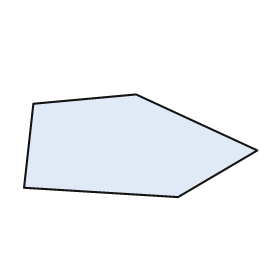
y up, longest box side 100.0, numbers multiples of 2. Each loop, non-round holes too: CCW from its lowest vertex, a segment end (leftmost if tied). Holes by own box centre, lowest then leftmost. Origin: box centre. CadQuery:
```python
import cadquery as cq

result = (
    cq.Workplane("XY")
    .moveTo(16.0, -22.0)
    .lineTo(50.0, -2.0)
    .lineTo(-2.0, 22.0)
    .lineTo(-46.0, 18.0)
    .lineTo(-50.0, -18.0)
    .close()
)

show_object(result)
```